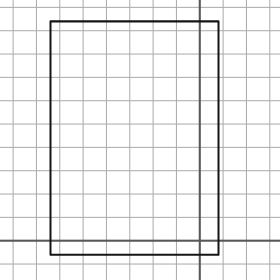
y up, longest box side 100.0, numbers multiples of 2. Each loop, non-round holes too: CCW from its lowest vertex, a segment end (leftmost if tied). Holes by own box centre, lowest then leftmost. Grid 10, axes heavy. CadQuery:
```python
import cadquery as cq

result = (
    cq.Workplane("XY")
    .moveTo(-64.0, -6.0)
    .lineTo(8.0, -6.0)
    .lineTo(8.0, 94.0)
    .lineTo(-64.0, 94.0)
    .close()
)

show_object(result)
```